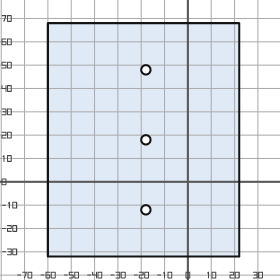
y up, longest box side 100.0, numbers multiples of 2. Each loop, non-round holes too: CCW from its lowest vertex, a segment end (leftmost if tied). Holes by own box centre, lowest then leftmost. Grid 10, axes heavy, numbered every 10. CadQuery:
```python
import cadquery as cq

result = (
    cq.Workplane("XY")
    .moveTo(-60.0, -32.0)
    .lineTo(22.0, -32.0)
    .lineTo(22.0, 68.0)
    .lineTo(-60.0, 68.0)
    .close()
    .moveTo(-18.0, -12.0)
    .circle(2.0)
    .moveTo(-18.0, 18.0)
    .circle(2.0)
    .moveTo(-18.0, 48.0)
    .circle(2.0)
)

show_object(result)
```